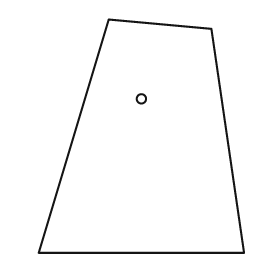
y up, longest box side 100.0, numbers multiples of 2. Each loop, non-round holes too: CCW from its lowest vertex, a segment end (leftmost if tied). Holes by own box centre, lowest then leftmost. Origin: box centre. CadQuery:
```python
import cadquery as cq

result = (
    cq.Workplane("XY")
    .moveTo(-44.0, -50.0)
    .lineTo(44.0, -50.0)
    .lineTo(30.0, 46.0)
    .lineTo(-14.0, 50.0)
    .close()
    .moveTo(0.0, 16.0)
    .circle(2.0)
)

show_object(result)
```